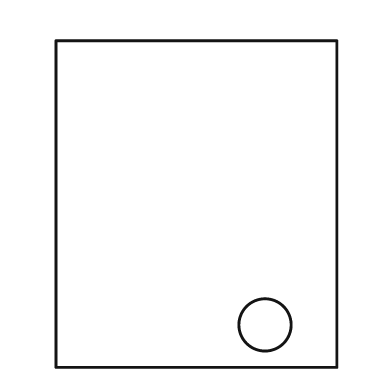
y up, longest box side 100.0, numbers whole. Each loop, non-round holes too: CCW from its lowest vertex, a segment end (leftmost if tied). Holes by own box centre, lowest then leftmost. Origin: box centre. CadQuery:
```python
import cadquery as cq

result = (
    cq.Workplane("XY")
    .moveTo(-43.0, -50.0)
    .lineTo(43.0, -50.0)
    .lineTo(43.0, 50.0)
    .lineTo(-43.0, 50.0)
    .close()
    .moveTo(21.0, -37.0)
    .circle(8.0)
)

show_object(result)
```